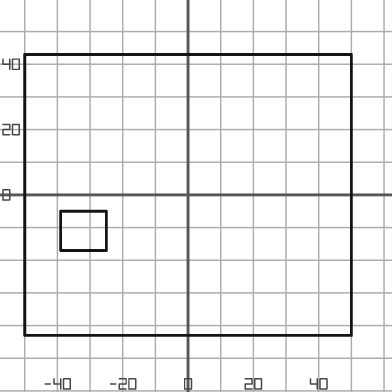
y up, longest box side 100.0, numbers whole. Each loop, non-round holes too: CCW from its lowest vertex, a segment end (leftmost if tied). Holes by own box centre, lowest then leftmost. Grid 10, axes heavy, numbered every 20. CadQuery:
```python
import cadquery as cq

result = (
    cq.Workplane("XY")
    .moveTo(-50.0, -43.0)
    .lineTo(50.0, -43.0)
    .lineTo(50.0, 43.0)
    .lineTo(-50.0, 43.0)
    .close()
    .moveTo(-39.0, -17.0)
    .lineTo(-25.0, -17.0)
    .lineTo(-25.0, -5.0)
    .lineTo(-39.0, -5.0)
    .close()
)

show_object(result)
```